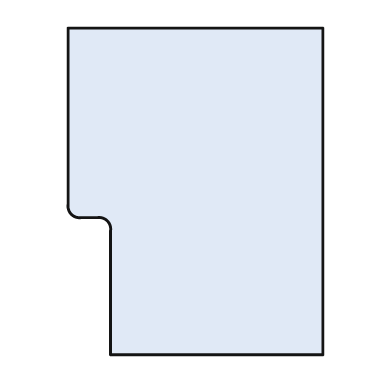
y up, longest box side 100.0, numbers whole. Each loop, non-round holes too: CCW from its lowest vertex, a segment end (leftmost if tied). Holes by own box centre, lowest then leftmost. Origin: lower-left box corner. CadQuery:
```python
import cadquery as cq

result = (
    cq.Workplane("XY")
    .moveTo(13.0, 0.0)
    .lineTo(78.0, 0.0)
    .lineTo(78.0, 100.0)
    .lineTo(0.0, 100.0)
    .lineTo(0.0, 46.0)
    .threePointArc((1.0, 43.0), (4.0, 42.0))
    .lineTo(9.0, 42.0)
    .threePointArc((12.0, 41.0), (13.0, 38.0))
    .close()
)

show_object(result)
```